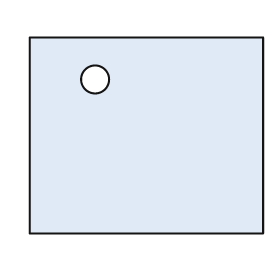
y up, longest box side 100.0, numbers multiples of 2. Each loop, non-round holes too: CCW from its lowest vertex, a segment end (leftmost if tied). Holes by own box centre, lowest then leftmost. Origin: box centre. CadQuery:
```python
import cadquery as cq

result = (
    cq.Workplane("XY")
    .moveTo(-50.0, -42.0)
    .lineTo(50.0, -42.0)
    .lineTo(50.0, 42.0)
    .lineTo(-50.0, 42.0)
    .close()
    .moveTo(-22.0, 24.0)
    .circle(6.0)
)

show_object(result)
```